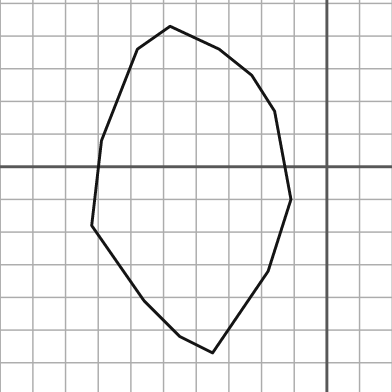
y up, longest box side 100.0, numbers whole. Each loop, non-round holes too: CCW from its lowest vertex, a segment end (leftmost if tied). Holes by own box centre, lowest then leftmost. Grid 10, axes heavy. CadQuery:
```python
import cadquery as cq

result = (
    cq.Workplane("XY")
    .moveTo(-35.0, -57.0)
    .lineTo(-18.0, -32.0)
    .lineTo(-11.0, -10.0)
    .lineTo(-16.0, 17.0)
    .lineTo(-23.0, 28.0)
    .lineTo(-33.0, 36.0)
    .lineTo(-48.0, 43.0)
    .lineTo(-58.0, 36.0)
    .lineTo(-69.0, 8.0)
    .lineTo(-72.0, -18.0)
    .lineTo(-56.0, -41.0)
    .lineTo(-45.0, -52.0)
    .close()
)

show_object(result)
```